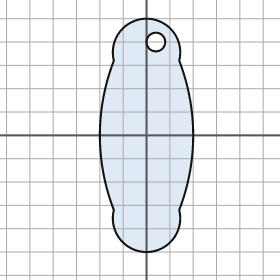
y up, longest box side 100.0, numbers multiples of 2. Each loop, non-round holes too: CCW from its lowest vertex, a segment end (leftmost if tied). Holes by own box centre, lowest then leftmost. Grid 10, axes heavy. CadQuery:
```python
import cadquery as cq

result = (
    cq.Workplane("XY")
    .moveTo(-14.0, -32.0)
    .threePointArc((0.0, -50.0), (14.0, -32.0))
    .threePointArc((20.0, 0.0), (14.0, 32.0))
    .threePointArc((0.0, 50.0), (-14.0, 32.0))
    .threePointArc((-20.0, 0.0), (-14.0, -32.0))
    .close()
    .moveTo(4.0, 40.0)
    .circle(4.0)
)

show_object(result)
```